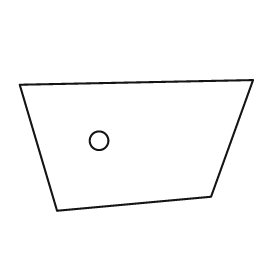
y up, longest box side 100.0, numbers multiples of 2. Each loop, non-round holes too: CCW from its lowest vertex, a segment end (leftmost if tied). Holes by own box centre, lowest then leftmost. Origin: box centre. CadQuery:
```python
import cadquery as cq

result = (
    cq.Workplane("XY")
    .moveTo(-34.0, -28.0)
    .lineTo(32.0, -22.0)
    .lineTo(50.0, 28.0)
    .lineTo(-50.0, 26.0)
    .close()
    .moveTo(-16.0, 2.0)
    .circle(4.0)
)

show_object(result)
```